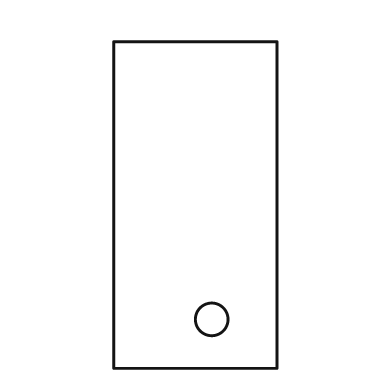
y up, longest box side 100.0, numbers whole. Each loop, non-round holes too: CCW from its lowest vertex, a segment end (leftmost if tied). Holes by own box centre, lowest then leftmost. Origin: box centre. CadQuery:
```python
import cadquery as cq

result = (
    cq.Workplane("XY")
    .moveTo(-25.0, -50.0)
    .lineTo(25.0, -50.0)
    .lineTo(25.0, 50.0)
    .lineTo(-25.0, 50.0)
    .close()
    .moveTo(5.0, -35.0)
    .circle(5.0)
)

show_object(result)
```